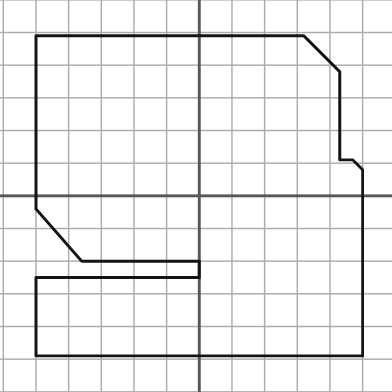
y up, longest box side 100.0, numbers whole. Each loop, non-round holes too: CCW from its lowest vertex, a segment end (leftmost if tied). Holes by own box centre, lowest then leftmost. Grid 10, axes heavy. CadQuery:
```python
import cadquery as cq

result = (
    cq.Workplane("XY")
    .moveTo(-50.0, -49.0)
    .lineTo(50.0, -49.0)
    .lineTo(50.0, 8.0)
    .lineTo(47.0, 11.0)
    .lineTo(43.0, 11.0)
    .lineTo(43.0, 38.0)
    .lineTo(32.0, 49.0)
    .lineTo(-50.0, 49.0)
    .lineTo(-50.0, -4.0)
    .lineTo(-36.0, -20.0)
    .lineTo(0.0, -20.0)
    .lineTo(0.0, -25.0)
    .lineTo(-50.0, -25.0)
    .close()
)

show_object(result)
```